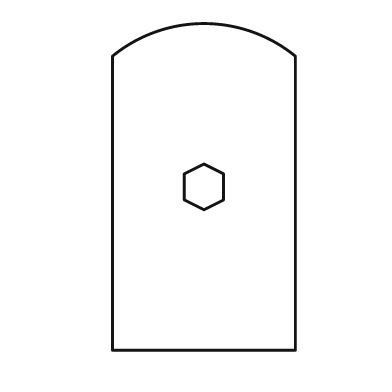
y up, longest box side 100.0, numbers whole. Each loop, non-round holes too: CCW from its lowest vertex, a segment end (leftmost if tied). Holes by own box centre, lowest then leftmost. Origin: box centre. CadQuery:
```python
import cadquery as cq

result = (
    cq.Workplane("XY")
    .moveTo(-28.0, -50.0)
    .lineTo(28.0, -50.0)
    .lineTo(28.0, 40.0)
    .threePointArc((0.0, 50.0), (-28.0, 40.0))
    .close()
    .moveTo(0.0, -7.0)
    .lineTo(6.0, -4.0)
    .lineTo(6.0, 4.0)
    .lineTo(0.0, 7.0)
    .lineTo(-6.0, 4.0)
    .lineTo(-6.0, -4.0)
    .close()
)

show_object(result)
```